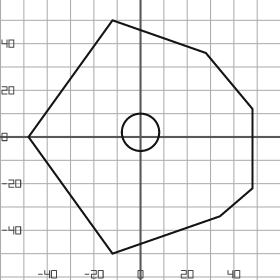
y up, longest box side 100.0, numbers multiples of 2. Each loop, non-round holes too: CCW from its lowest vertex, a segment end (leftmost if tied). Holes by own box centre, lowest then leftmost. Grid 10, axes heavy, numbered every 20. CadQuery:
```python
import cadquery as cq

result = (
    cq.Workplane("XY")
    .moveTo(-12.0, -50.0)
    .lineTo(34.0, -34.0)
    .lineTo(48.0, -22.0)
    .lineTo(48.0, 12.0)
    .lineTo(28.0, 36.0)
    .lineTo(-12.0, 50.0)
    .lineTo(-48.0, 0.0)
    .close()
    .moveTo(0.0, 2.0)
    .circle(8.0)
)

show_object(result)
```